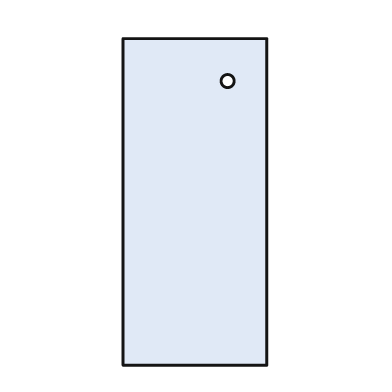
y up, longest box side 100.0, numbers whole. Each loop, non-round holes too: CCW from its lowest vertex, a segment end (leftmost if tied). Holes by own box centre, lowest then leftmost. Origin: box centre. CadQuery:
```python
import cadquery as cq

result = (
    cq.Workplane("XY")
    .moveTo(-22.0, -50.0)
    .lineTo(22.0, -50.0)
    .lineTo(22.0, 50.0)
    .lineTo(-22.0, 50.0)
    .close()
    .moveTo(10.0, 37.0)
    .circle(2.0)
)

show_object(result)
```